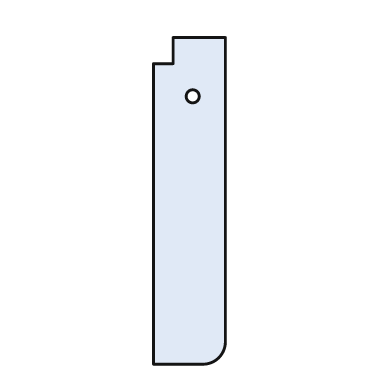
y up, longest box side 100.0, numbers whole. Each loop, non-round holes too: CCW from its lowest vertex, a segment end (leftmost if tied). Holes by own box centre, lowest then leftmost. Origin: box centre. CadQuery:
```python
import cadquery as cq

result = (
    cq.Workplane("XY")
    .moveTo(-11.0, -50.0)
    .lineTo(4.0, -50.0)
    .threePointArc((9.0, -48.0), (11.0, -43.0))
    .lineTo(11.0, 50.0)
    .lineTo(-5.0, 50.0)
    .lineTo(-5.0, 42.0)
    .lineTo(-11.0, 42.0)
    .close()
    .moveTo(1.0, 32.0)
    .circle(2.0)
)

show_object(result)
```